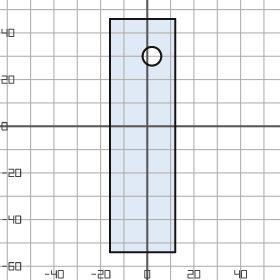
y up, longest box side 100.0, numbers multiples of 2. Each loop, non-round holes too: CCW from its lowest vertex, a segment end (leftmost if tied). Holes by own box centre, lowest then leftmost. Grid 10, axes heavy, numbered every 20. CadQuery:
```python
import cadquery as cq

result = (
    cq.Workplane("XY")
    .moveTo(-16.0, -54.0)
    .lineTo(12.0, -54.0)
    .lineTo(12.0, 46.0)
    .lineTo(-16.0, 46.0)
    .close()
    .moveTo(2.0, 30.0)
    .circle(4.0)
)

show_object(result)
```